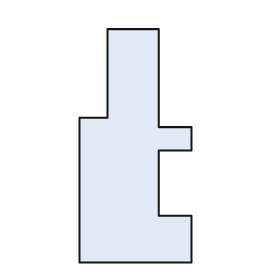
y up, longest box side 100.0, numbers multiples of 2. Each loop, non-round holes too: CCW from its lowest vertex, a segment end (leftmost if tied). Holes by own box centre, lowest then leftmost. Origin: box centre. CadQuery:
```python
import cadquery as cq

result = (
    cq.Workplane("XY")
    .moveTo(-24.0, -50.0)
    .lineTo(24.0, -50.0)
    .lineTo(24.0, -30.0)
    .lineTo(10.0, -30.0)
    .lineTo(10.0, -2.0)
    .lineTo(24.0, -2.0)
    .lineTo(24.0, 8.0)
    .lineTo(10.0, 8.0)
    .lineTo(10.0, 50.0)
    .lineTo(-12.0, 50.0)
    .lineTo(-12.0, 12.0)
    .lineTo(-24.0, 12.0)
    .close()
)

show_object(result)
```